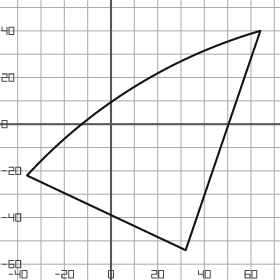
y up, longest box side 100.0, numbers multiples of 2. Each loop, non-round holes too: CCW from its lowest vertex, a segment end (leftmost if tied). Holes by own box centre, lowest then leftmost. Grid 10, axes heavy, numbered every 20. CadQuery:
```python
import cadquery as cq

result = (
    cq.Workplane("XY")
    .moveTo(32.0, -54.0)
    .lineTo(64.0, 40.0)
    .threePointArc((10.0, 16.0), (-36.0, -22.0))
    .close()
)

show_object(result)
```